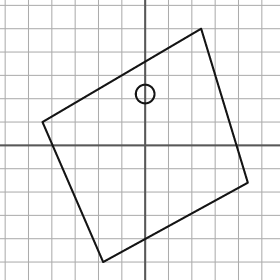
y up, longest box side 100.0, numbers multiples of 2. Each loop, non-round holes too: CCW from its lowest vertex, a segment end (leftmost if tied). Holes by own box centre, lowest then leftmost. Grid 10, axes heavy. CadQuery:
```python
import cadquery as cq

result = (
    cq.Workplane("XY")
    .moveTo(-18.0, -50.0)
    .lineTo(44.0, -16.0)
    .lineTo(24.0, 50.0)
    .lineTo(-44.0, 10.0)
    .close()
    .moveTo(0.0, 22.0)
    .circle(4.0)
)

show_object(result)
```